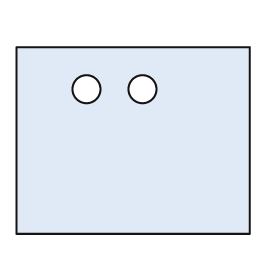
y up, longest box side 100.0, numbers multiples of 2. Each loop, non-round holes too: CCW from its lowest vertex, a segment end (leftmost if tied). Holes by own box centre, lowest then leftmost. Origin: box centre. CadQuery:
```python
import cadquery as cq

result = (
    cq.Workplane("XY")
    .moveTo(-50.0, -40.0)
    .lineTo(50.0, -40.0)
    .lineTo(50.0, 40.0)
    .lineTo(-50.0, 40.0)
    .close()
    .moveTo(-20.0, 22.0)
    .circle(6.0)
    .moveTo(4.0, 22.0)
    .circle(6.0)
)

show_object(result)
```